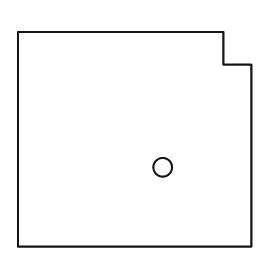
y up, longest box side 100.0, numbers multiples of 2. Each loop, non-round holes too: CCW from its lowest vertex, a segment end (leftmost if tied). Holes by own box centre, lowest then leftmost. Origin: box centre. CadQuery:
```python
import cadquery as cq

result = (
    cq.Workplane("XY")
    .moveTo(-50.0, -46.0)
    .lineTo(50.0, -46.0)
    .lineTo(50.0, 32.0)
    .lineTo(38.0, 32.0)
    .lineTo(38.0, 46.0)
    .lineTo(-50.0, 46.0)
    .close()
    .moveTo(12.0, -12.0)
    .circle(4.0)
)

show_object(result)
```